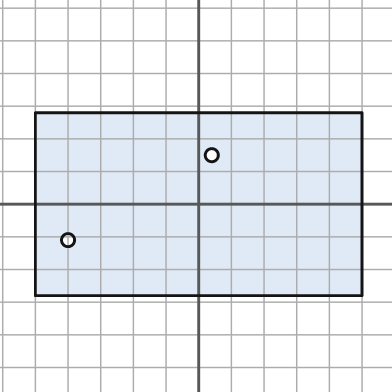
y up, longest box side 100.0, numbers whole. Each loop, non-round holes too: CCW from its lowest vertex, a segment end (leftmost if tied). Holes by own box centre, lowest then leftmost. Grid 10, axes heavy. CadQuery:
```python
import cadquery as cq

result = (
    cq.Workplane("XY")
    .moveTo(-50.0, -28.0)
    .lineTo(50.0, -28.0)
    .lineTo(50.0, 28.0)
    .lineTo(-50.0, 28.0)
    .close()
    .moveTo(-40.0, -11.0)
    .circle(2.0)
    .moveTo(4.0, 15.0)
    .circle(2.0)
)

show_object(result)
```